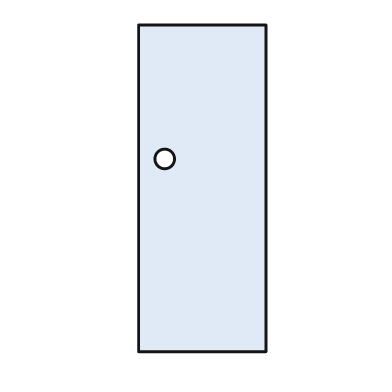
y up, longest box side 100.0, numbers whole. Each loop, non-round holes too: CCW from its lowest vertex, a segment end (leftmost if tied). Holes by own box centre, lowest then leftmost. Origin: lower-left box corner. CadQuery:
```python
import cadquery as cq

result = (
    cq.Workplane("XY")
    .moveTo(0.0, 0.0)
    .lineTo(39.0, 0.0)
    .lineTo(39.0, 100.0)
    .lineTo(0.0, 100.0)
    .close()
    .moveTo(8.0, 59.0)
    .circle(3.0)
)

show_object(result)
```